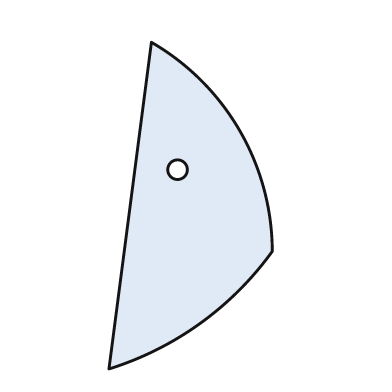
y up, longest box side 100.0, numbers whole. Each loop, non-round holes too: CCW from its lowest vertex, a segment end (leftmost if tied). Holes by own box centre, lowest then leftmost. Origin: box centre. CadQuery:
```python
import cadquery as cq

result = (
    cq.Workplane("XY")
    .moveTo(-25.0, -50.0)
    .threePointArc((3.0, -36.0), (25.0, -14.0))
    .threePointArc((15.0, 23.0), (-12.0, 50.0))
    .close()
    .moveTo(-4.0, 11.0)
    .circle(3.0)
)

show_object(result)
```